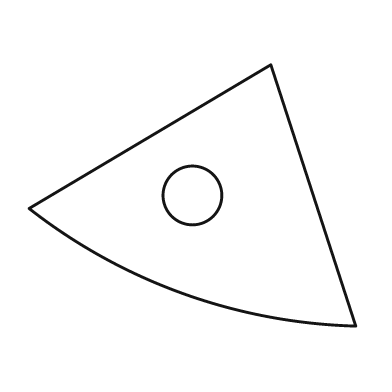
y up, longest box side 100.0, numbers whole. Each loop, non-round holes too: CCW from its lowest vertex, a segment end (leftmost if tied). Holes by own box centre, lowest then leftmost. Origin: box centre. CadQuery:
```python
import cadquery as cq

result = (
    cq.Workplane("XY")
    .moveTo(50.0, -40.0)
    .lineTo(24.0, 40.0)
    .lineTo(-50.0, -4.0)
    .threePointArc((-3.0, -30.0), (50.0, -40.0))
    .close()
    .moveTo(0.0, 0.0)
    .circle(9.0)
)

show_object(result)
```